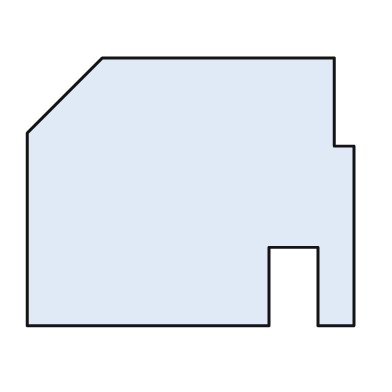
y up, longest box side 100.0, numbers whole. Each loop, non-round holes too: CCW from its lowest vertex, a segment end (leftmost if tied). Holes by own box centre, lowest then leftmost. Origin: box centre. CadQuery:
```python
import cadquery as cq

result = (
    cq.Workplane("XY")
    .moveTo(-50.0, -41.0)
    .lineTo(24.0, -41.0)
    .lineTo(24.0, -17.0)
    .lineTo(39.0, -17.0)
    .lineTo(39.0, -41.0)
    .lineTo(50.0, -41.0)
    .lineTo(50.0, 14.0)
    .lineTo(44.0, 14.0)
    .lineTo(44.0, 41.0)
    .lineTo(-27.0, 41.0)
    .lineTo(-50.0, 18.0)
    .close()
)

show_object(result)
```